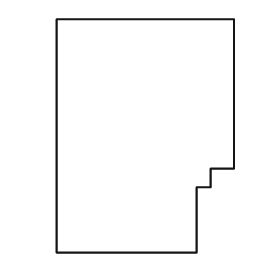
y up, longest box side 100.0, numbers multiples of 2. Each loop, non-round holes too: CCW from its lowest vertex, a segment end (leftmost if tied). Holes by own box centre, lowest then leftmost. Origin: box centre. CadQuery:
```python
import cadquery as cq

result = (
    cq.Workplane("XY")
    .moveTo(-38.0, -50.0)
    .lineTo(22.0, -50.0)
    .lineTo(22.0, -22.0)
    .lineTo(28.0, -22.0)
    .lineTo(28.0, -14.0)
    .lineTo(38.0, -14.0)
    .lineTo(38.0, 50.0)
    .lineTo(-38.0, 50.0)
    .close()
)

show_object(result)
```